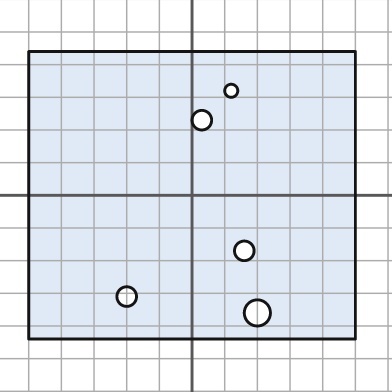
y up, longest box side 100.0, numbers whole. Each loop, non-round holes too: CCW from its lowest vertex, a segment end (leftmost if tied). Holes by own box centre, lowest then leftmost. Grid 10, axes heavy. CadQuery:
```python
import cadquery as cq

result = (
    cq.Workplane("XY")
    .moveTo(-50.0, -44.0)
    .lineTo(50.0, -44.0)
    .lineTo(50.0, 44.0)
    .lineTo(-50.0, 44.0)
    .close()
    .moveTo(20.0, -36.0)
    .circle(4.0)
    .moveTo(-20.0, -31.0)
    .circle(3.0)
    .moveTo(16.0, -17.0)
    .circle(3.0)
    .moveTo(3.0, 23.0)
    .circle(3.0)
    .moveTo(12.0, 32.0)
    .circle(2.0)
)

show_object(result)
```